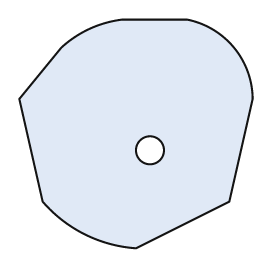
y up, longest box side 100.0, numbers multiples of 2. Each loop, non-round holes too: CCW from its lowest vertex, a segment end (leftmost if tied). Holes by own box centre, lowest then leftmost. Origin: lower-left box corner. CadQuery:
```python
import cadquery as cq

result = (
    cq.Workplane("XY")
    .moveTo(50.0, 0.0)
    .lineTo(90.0, 20.0)
    .lineTo(100.0, 64.0)
    .threePointArc((92.0, 86.0), (72.0, 98.0))
    .lineTo(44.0, 98.0)
    .threePointArc((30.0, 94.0), (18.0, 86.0))
    .lineTo(0.0, 64.0)
    .lineTo(10.0, 20.0)
    .threePointArc((28.0, 6.0), (50.0, 0.0))
    .close()
    .moveTo(56.0, 42.0)
    .circle(6.0)
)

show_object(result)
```